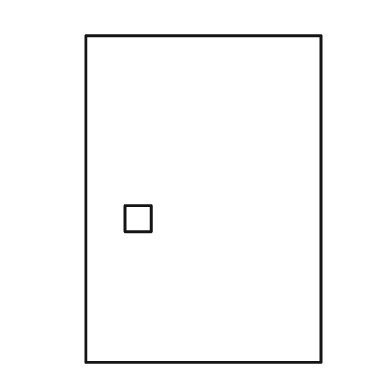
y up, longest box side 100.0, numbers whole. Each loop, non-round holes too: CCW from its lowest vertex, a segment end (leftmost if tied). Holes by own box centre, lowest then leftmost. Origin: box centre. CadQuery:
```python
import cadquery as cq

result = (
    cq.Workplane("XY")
    .moveTo(-36.0, -50.0)
    .lineTo(36.0, -50.0)
    .lineTo(36.0, 50.0)
    .lineTo(-36.0, 50.0)
    .close()
    .moveTo(-24.0, -10.0)
    .lineTo(-16.0, -10.0)
    .lineTo(-16.0, -2.0)
    .lineTo(-24.0, -2.0)
    .close()
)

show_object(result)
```